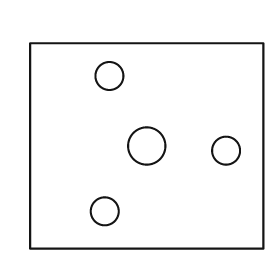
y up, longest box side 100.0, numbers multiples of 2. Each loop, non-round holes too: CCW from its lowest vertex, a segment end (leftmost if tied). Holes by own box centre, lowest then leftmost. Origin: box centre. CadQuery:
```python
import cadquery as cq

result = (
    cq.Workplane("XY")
    .moveTo(-50.0, -44.0)
    .lineTo(50.0, -44.0)
    .lineTo(50.0, 44.0)
    .lineTo(-50.0, 44.0)
    .close()
    .moveTo(-18.0, -28.0)
    .circle(6.0)
    .moveTo(34.0, -2.0)
    .circle(6.0)
    .moveTo(0.0, 0.0)
    .circle(8.0)
    .moveTo(-16.0, 30.0)
    .circle(6.0)
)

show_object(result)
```